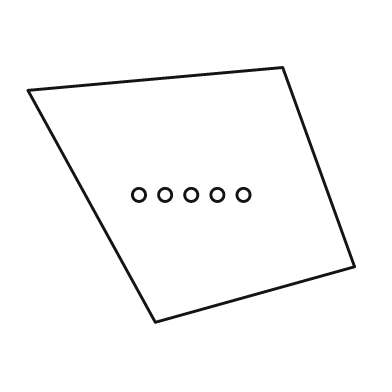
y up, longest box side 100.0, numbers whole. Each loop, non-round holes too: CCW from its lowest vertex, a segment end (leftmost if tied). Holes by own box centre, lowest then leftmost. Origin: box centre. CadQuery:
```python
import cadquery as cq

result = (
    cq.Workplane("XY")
    .moveTo(-11.0, -39.0)
    .lineTo(50.0, -22.0)
    .lineTo(28.0, 39.0)
    .lineTo(-50.0, 32.0)
    .close()
    .moveTo(-16.0, 0.0)
    .circle(2.0)
    .moveTo(-8.0, 0.0)
    .circle(2.0)
    .moveTo(0.0, 0.0)
    .circle(2.0)
    .moveTo(8.0, 0.0)
    .circle(2.0)
    .moveTo(16.0, 0.0)
    .circle(2.0)
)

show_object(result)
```